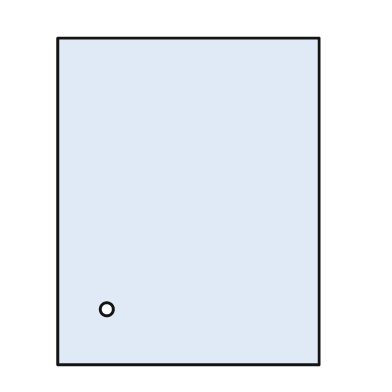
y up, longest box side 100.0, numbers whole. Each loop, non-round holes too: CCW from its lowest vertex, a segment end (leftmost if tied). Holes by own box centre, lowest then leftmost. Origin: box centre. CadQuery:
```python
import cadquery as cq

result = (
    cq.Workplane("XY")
    .moveTo(-40.0, -50.0)
    .lineTo(40.0, -50.0)
    .lineTo(40.0, 50.0)
    .lineTo(-40.0, 50.0)
    .close()
    .moveTo(-25.0, -33.0)
    .circle(2.0)
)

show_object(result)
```